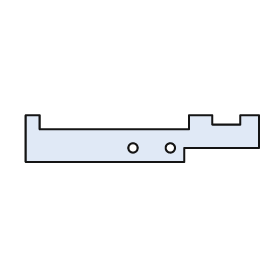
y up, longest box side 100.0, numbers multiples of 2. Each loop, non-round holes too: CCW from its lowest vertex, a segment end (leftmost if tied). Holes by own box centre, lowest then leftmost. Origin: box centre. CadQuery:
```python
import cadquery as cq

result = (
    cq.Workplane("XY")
    .moveTo(-50.0, -10.0)
    .lineTo(18.0, -10.0)
    .lineTo(18.0, -4.0)
    .lineTo(50.0, -4.0)
    .lineTo(50.0, 10.0)
    .lineTo(42.0, 10.0)
    .lineTo(42.0, 6.0)
    .lineTo(30.0, 6.0)
    .lineTo(30.0, 10.0)
    .lineTo(20.0, 10.0)
    .lineTo(20.0, 4.0)
    .lineTo(-44.0, 4.0)
    .lineTo(-44.0, 10.0)
    .lineTo(-50.0, 10.0)
    .close()
    .moveTo(-4.0, -4.0)
    .circle(2.0)
    .moveTo(12.0, -4.0)
    .circle(2.0)
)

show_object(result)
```